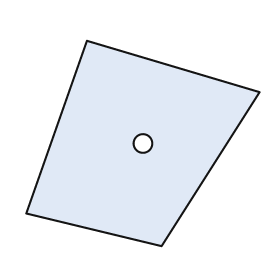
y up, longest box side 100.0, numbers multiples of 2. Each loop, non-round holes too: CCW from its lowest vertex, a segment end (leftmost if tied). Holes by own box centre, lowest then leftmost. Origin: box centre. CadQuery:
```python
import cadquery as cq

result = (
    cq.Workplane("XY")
    .moveTo(8.0, -44.0)
    .lineTo(50.0, 22.0)
    .lineTo(-24.0, 44.0)
    .lineTo(-50.0, -30.0)
    .close()
    .moveTo(0.0, 0.0)
    .circle(4.0)
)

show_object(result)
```